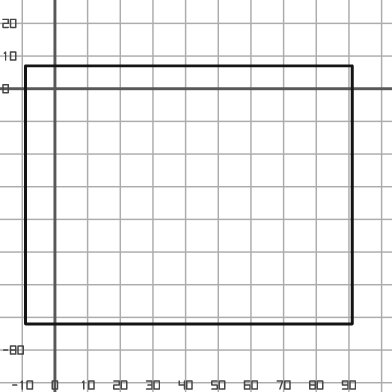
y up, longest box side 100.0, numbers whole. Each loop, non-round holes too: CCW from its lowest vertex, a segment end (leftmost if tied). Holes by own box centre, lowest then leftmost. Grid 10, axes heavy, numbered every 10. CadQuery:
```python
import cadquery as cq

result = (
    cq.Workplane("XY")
    .moveTo(-9.0, -72.0)
    .lineTo(91.0, -72.0)
    .lineTo(91.0, 7.0)
    .lineTo(-9.0, 7.0)
    .close()
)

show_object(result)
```